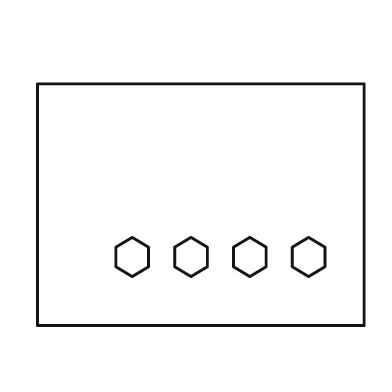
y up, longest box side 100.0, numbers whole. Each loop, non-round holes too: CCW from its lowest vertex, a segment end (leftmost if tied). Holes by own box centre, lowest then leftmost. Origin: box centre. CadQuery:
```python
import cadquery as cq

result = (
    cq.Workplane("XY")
    .moveTo(-50.0, -37.0)
    .lineTo(50.0, -37.0)
    .lineTo(50.0, 37.0)
    .lineTo(-50.0, 37.0)
    .close()
    .moveTo(-21.0, -22.0)
    .lineTo(-16.0, -19.0)
    .lineTo(-16.0, -13.0)
    .lineTo(-21.0, -10.0)
    .lineTo(-26.0, -13.0)
    .lineTo(-26.0, -19.0)
    .close()
    .moveTo(-3.0, -22.0)
    .lineTo(2.0, -19.0)
    .lineTo(2.0, -13.0)
    .lineTo(-3.0, -10.0)
    .lineTo(-8.0, -13.0)
    .lineTo(-8.0, -19.0)
    .close()
    .moveTo(15.0, -22.0)
    .lineTo(20.0, -19.0)
    .lineTo(20.0, -13.0)
    .lineTo(15.0, -10.0)
    .lineTo(10.0, -13.0)
    .lineTo(10.0, -19.0)
    .close()
    .moveTo(33.0, -22.0)
    .lineTo(38.0, -19.0)
    .lineTo(38.0, -13.0)
    .lineTo(33.0, -10.0)
    .lineTo(28.0, -13.0)
    .lineTo(28.0, -19.0)
    .close()
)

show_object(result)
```